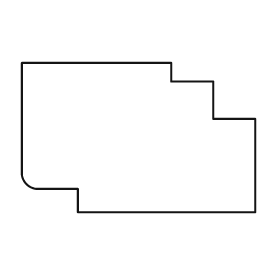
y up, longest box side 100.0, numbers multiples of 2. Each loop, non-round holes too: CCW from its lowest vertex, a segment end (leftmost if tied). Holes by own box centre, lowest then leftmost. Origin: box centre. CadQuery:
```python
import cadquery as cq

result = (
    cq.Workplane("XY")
    .moveTo(-26.0, -32.0)
    .lineTo(50.0, -32.0)
    .lineTo(50.0, 8.0)
    .lineTo(32.0, 8.0)
    .lineTo(32.0, 24.0)
    .lineTo(14.0, 24.0)
    .lineTo(14.0, 32.0)
    .lineTo(-50.0, 32.0)
    .lineTo(-50.0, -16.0)
    .threePointArc((-48.0, -20.0), (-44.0, -22.0))
    .lineTo(-26.0, -22.0)
    .close()
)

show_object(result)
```